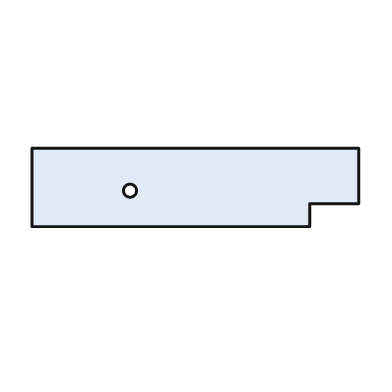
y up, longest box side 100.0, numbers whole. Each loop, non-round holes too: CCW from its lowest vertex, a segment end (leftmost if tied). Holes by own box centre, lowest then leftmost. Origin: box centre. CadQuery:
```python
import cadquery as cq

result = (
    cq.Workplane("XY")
    .moveTo(-50.0, -12.0)
    .lineTo(35.0, -12.0)
    .lineTo(35.0, -5.0)
    .lineTo(50.0, -5.0)
    .lineTo(50.0, 12.0)
    .lineTo(-50.0, 12.0)
    .close()
    .moveTo(-20.0, -1.0)
    .circle(2.0)
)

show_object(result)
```